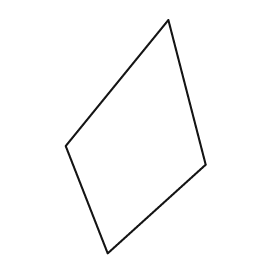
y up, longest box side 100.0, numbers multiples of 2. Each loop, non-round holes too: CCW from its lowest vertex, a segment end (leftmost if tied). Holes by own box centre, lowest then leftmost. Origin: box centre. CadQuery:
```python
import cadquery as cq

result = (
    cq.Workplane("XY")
    .moveTo(-12.0, -50.0)
    .lineTo(30.0, -12.0)
    .lineTo(14.0, 50.0)
    .lineTo(-30.0, -4.0)
    .close()
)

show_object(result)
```